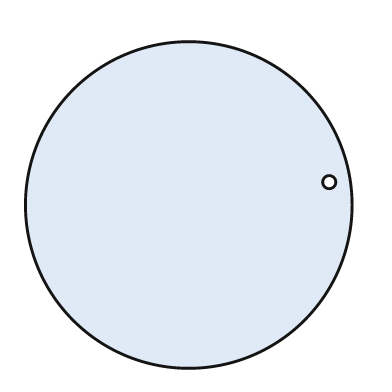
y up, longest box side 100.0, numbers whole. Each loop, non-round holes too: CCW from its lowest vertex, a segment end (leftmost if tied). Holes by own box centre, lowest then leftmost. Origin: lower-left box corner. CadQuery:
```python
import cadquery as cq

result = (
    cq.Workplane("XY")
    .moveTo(50.0, 50.0)
    .circle(50.0)
    .moveTo(93.0, 57.0)
    .circle(2.0)
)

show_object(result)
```